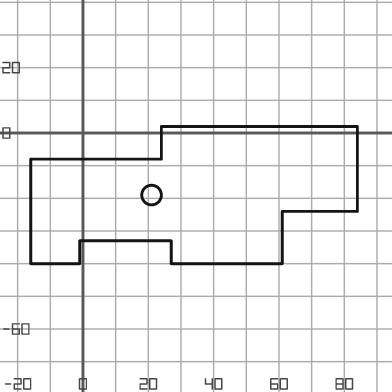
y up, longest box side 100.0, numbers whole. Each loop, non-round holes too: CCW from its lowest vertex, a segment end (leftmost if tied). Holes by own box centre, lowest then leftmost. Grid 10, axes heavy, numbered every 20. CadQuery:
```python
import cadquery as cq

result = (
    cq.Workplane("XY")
    .moveTo(-16.0, -40.0)
    .lineTo(-1.0, -40.0)
    .lineTo(-1.0, -33.0)
    .lineTo(27.0, -33.0)
    .lineTo(27.0, -40.0)
    .lineTo(61.0, -40.0)
    .lineTo(61.0, -24.0)
    .lineTo(84.0, -24.0)
    .lineTo(84.0, 2.0)
    .lineTo(24.0, 2.0)
    .lineTo(24.0, -8.0)
    .lineTo(-16.0, -8.0)
    .close()
    .moveTo(21.0, -19.0)
    .circle(3.0)
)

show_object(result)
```